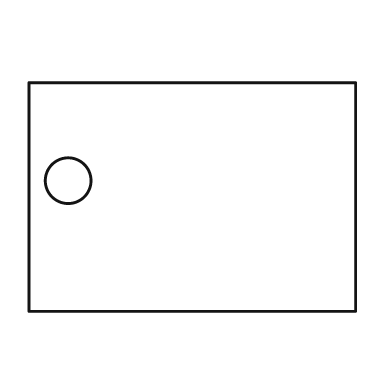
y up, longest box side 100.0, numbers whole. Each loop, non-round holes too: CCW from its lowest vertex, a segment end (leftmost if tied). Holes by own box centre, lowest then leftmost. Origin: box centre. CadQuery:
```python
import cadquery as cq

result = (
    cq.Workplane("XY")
    .moveTo(-50.0, -35.0)
    .lineTo(50.0, -35.0)
    .lineTo(50.0, 35.0)
    .lineTo(-50.0, 35.0)
    .close()
    .moveTo(-38.0, 5.0)
    .circle(7.0)
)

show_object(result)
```